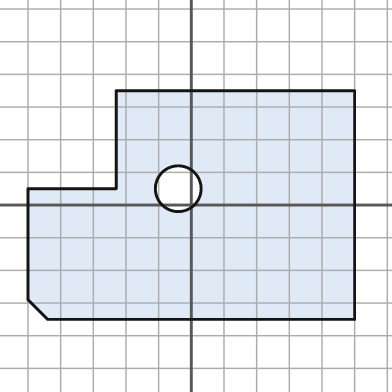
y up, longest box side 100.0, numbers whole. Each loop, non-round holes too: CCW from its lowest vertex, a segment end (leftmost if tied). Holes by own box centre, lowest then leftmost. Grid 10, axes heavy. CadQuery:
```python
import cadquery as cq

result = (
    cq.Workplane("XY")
    .moveTo(-44.0, -35.0)
    .lineTo(50.0, -35.0)
    .lineTo(50.0, 35.0)
    .lineTo(-23.0, 35.0)
    .lineTo(-23.0, 5.0)
    .lineTo(-50.0, 5.0)
    .lineTo(-50.0, -29.0)
    .close()
    .moveTo(-4.0, 5.0)
    .circle(7.0)
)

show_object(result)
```